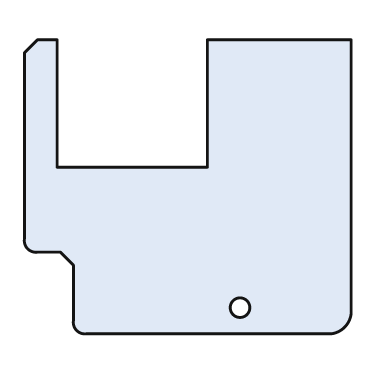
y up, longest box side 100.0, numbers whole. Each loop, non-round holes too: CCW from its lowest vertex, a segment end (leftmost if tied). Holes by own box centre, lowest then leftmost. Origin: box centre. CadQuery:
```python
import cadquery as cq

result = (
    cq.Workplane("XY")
    .moveTo(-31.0, -45.0)
    .lineTo(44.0, -45.0)
    .threePointArc((48.0, -43.0), (50.0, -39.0))
    .lineTo(50.0, 45.0)
    .lineTo(6.0, 45.0)
    .lineTo(6.0, 6.0)
    .lineTo(-40.0, 6.0)
    .lineTo(-40.0, 45.0)
    .lineTo(-46.0, 45.0)
    .lineTo(-50.0, 41.0)
    .lineTo(-50.0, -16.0)
    .threePointArc((-49.0, -19.0), (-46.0, -20.0))
    .lineTo(-39.0, -20.0)
    .lineTo(-35.0, -24.0)
    .lineTo(-35.0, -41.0)
    .threePointArc((-34.0, -44.0), (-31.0, -45.0))
    .close()
    .moveTo(16.0, -37.0)
    .circle(3.0)
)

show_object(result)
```